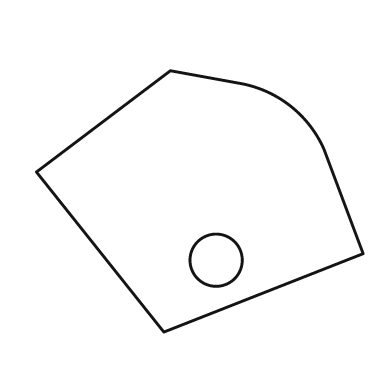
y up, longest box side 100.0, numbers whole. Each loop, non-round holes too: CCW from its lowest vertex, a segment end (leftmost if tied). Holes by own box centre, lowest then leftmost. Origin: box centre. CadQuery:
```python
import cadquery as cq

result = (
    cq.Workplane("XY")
    .moveTo(-11.0, -40.0)
    .lineTo(50.0, -16.0)
    .lineTo(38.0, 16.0)
    .threePointArc((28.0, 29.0), (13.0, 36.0))
    .lineTo(-9.0, 40.0)
    .lineTo(-50.0, 9.0)
    .close()
    .moveTo(5.0, -18.0)
    .circle(8.0)
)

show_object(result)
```